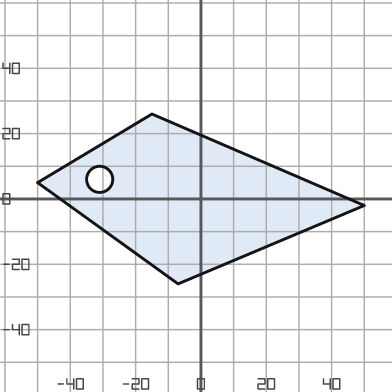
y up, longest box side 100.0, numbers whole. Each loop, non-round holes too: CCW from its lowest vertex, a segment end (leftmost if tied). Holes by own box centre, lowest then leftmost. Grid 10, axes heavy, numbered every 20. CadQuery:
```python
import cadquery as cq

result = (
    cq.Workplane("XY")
    .moveTo(-7.0, -26.0)
    .lineTo(50.0, -2.0)
    .lineTo(-15.0, 26.0)
    .lineTo(-50.0, 5.0)
    .close()
    .moveTo(-31.0, 6.0)
    .circle(4.0)
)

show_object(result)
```